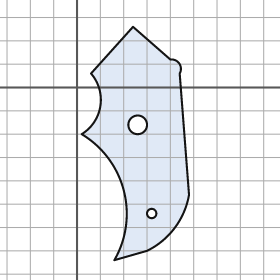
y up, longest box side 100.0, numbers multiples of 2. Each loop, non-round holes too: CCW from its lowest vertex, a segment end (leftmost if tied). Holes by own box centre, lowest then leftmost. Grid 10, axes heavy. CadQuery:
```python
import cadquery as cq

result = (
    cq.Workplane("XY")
    .moveTo(16.0, -74.0)
    .lineTo(30.0, -70.0)
    .threePointArc((42.0, -60.0), (48.0, -46.0))
    .lineTo(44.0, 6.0)
    .threePointArc((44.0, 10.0), (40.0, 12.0))
    .lineTo(24.0, 26.0)
    .lineTo(6.0, 6.0)
    .threePointArc((10.0, -8.0), (2.0, -20.0))
    .threePointArc((20.0, -44.0), (16.0, -74.0))
    .close()
    .moveTo(32.0, -54.0)
    .circle(2.0)
    .moveTo(26.0, -16.0)
    .circle(4.0)
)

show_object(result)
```